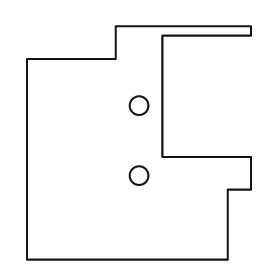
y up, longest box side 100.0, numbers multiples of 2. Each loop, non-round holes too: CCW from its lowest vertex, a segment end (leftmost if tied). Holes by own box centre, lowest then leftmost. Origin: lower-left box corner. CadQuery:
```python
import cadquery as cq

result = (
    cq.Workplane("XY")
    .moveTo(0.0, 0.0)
    .lineTo(86.0, 0.0)
    .lineTo(86.0, 30.0)
    .lineTo(96.0, 30.0)
    .lineTo(96.0, 44.0)
    .lineTo(58.0, 44.0)
    .lineTo(58.0, 96.0)
    .lineTo(96.0, 96.0)
    .lineTo(96.0, 100.0)
    .lineTo(38.0, 100.0)
    .lineTo(38.0, 86.0)
    .lineTo(0.0, 86.0)
    .close()
    .moveTo(48.0, 36.0)
    .circle(4.0)
    .moveTo(48.0, 66.0)
    .circle(4.0)
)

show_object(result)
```